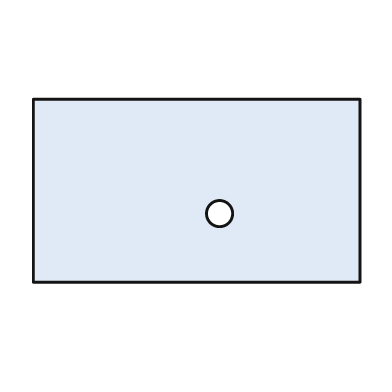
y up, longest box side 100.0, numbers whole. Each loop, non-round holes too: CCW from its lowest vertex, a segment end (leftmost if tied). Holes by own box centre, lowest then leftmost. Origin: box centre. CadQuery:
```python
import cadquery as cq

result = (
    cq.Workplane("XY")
    .moveTo(-50.0, -28.0)
    .lineTo(50.0, -28.0)
    .lineTo(50.0, 28.0)
    .lineTo(-50.0, 28.0)
    .close()
    .moveTo(7.0, -7.0)
    .circle(4.0)
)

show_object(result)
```